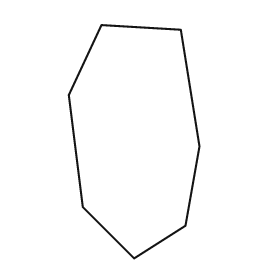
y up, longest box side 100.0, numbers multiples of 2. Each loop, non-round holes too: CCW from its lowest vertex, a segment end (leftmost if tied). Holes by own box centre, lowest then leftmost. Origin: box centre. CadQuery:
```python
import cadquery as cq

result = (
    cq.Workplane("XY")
    .moveTo(0.0, -50.0)
    .lineTo(22.0, -36.0)
    .lineTo(28.0, -2.0)
    .lineTo(20.0, 48.0)
    .lineTo(-14.0, 50.0)
    .lineTo(-28.0, 20.0)
    .lineTo(-22.0, -28.0)
    .close()
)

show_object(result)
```